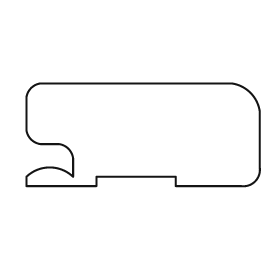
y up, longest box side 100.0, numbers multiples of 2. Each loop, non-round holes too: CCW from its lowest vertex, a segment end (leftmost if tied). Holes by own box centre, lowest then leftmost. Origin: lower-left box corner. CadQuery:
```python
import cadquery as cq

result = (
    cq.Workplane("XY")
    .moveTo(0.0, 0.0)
    .lineTo(30.0, 0.0)
    .lineTo(30.0, 4.0)
    .lineTo(64.0, 4.0)
    .lineTo(64.0, 0.0)
    .lineTo(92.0, 0.0)
    .threePointArc((98.0, 2.0), (100.0, 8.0))
    .lineTo(100.0, 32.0)
    .threePointArc((96.0, 40.0), (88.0, 44.0))
    .lineTo(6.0, 44.0)
    .threePointArc((2.0, 42.0), (0.0, 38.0))
    .lineTo(0.0, 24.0)
    .threePointArc((2.0, 20.0), (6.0, 18.0))
    .lineTo(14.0, 18.0)
    .threePointArc((18.0, 16.0), (20.0, 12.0))
    .lineTo(20.0, 4.0)
    .threePointArc((10.0, 8.0), (0.0, 4.0))
    .close()
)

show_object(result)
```